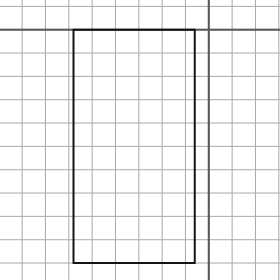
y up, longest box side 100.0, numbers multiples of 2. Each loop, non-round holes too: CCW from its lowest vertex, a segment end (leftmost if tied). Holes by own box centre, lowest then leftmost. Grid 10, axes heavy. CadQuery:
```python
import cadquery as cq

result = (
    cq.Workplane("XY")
    .moveTo(-58.0, -100.0)
    .lineTo(-6.0, -100.0)
    .lineTo(-6.0, 0.0)
    .lineTo(-58.0, 0.0)
    .close()
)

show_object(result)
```